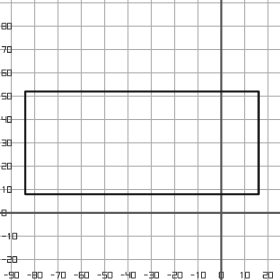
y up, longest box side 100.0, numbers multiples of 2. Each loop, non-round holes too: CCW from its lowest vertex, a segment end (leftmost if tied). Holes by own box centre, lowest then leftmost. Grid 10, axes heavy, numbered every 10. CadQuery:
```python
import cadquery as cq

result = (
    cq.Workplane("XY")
    .moveTo(-84.0, 8.0)
    .lineTo(16.0, 8.0)
    .lineTo(16.0, 52.0)
    .lineTo(-84.0, 52.0)
    .close()
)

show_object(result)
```